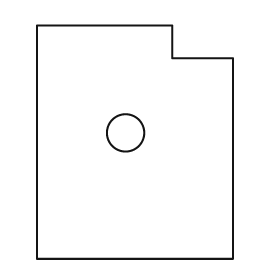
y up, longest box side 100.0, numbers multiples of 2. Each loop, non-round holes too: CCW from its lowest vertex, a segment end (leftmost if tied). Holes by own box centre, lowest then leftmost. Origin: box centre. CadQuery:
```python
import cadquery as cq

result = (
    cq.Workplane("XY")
    .moveTo(-42.0, -50.0)
    .lineTo(42.0, -50.0)
    .lineTo(42.0, 36.0)
    .lineTo(16.0, 36.0)
    .lineTo(16.0, 50.0)
    .lineTo(-42.0, 50.0)
    .close()
    .moveTo(-4.0, 4.0)
    .circle(8.0)
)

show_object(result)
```